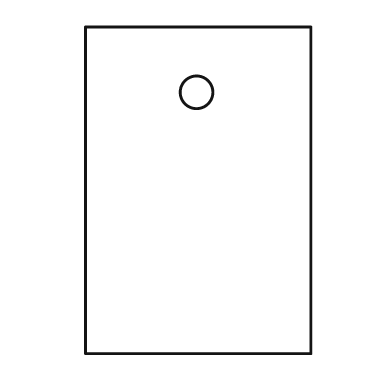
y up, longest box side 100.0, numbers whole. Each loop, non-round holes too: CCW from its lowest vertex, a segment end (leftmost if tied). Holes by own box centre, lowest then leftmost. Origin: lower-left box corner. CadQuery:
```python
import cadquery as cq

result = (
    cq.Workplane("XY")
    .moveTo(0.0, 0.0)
    .lineTo(69.0, 0.0)
    .lineTo(69.0, 100.0)
    .lineTo(0.0, 100.0)
    .close()
    .moveTo(34.0, 80.0)
    .circle(5.0)
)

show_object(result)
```